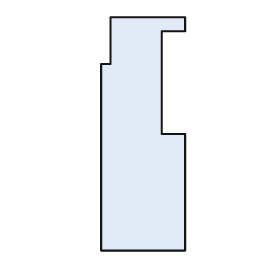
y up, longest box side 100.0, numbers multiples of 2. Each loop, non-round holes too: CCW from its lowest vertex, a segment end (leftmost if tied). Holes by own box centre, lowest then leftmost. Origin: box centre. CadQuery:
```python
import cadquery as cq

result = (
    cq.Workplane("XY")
    .moveTo(-18.0, -50.0)
    .lineTo(18.0, -50.0)
    .lineTo(18.0, 0.0)
    .lineTo(8.0, 0.0)
    .lineTo(8.0, 44.0)
    .lineTo(18.0, 44.0)
    .lineTo(18.0, 50.0)
    .lineTo(-14.0, 50.0)
    .lineTo(-14.0, 30.0)
    .lineTo(-18.0, 30.0)
    .close()
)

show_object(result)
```